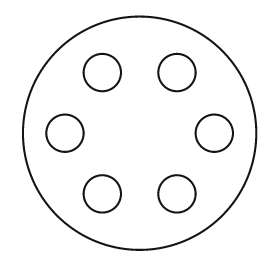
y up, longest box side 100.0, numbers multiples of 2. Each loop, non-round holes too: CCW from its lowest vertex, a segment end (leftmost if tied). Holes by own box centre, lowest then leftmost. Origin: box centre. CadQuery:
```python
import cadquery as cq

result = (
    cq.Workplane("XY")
    .moveTo(0.0, 0.0)
    .circle(50.0)
    .moveTo(-16.0, -26.0)
    .circle(8.0)
    .moveTo(16.0, -26.0)
    .circle(8.0)
    .moveTo(-32.0, 0.0)
    .circle(8.0)
    .moveTo(32.0, 0.0)
    .circle(8.0)
    .moveTo(-16.0, 26.0)
    .circle(8.0)
    .moveTo(16.0, 26.0)
    .circle(8.0)
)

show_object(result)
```